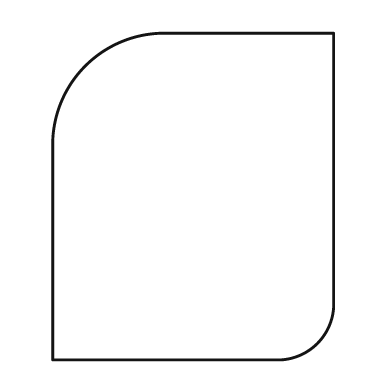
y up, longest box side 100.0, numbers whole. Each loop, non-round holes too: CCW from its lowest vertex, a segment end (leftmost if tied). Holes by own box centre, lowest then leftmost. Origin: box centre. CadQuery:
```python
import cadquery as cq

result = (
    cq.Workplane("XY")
    .moveTo(-43.0, -50.0)
    .lineTo(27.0, -50.0)
    .threePointArc((38.0, -45.0), (43.0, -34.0))
    .lineTo(43.0, 50.0)
    .lineTo(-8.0, 50.0)
    .threePointArc((-33.0, 40.0), (-43.0, 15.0))
    .close()
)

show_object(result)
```